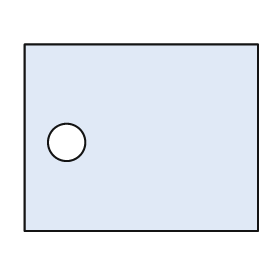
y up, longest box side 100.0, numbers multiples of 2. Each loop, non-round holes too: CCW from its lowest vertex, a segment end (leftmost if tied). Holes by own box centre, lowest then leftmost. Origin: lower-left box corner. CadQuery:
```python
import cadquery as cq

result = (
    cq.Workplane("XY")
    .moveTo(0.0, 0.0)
    .lineTo(100.0, 0.0)
    .lineTo(100.0, 80.0)
    .lineTo(0.0, 80.0)
    .close()
    .moveTo(18.0, 38.0)
    .circle(8.0)
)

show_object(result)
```